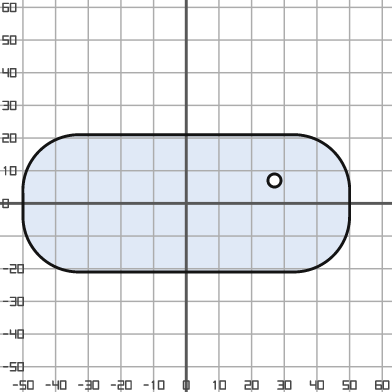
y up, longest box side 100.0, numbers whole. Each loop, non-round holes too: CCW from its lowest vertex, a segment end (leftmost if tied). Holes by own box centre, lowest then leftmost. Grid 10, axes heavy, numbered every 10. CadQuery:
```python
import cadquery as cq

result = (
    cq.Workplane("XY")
    .moveTo(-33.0, -21.0)
    .lineTo(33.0, -21.0)
    .threePointArc((45.0, -16.0), (50.0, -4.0))
    .lineTo(50.0, 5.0)
    .threePointArc((45.0, 16.0), (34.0, 21.0))
    .lineTo(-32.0, 21.0)
    .threePointArc((-45.0, 16.0), (-50.0, 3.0))
    .lineTo(-50.0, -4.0)
    .threePointArc((-45.0, -16.0), (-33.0, -21.0))
    .close()
    .moveTo(27.0, 7.0)
    .circle(2.0)
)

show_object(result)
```